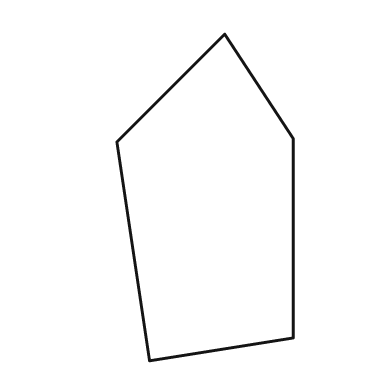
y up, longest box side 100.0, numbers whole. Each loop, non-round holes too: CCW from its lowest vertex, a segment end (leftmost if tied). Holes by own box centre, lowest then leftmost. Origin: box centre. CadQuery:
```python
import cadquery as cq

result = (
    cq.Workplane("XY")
    .moveTo(-17.0, -50.0)
    .lineTo(27.0, -43.0)
    .lineTo(27.0, 18.0)
    .lineTo(6.0, 50.0)
    .lineTo(-27.0, 17.0)
    .close()
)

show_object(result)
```